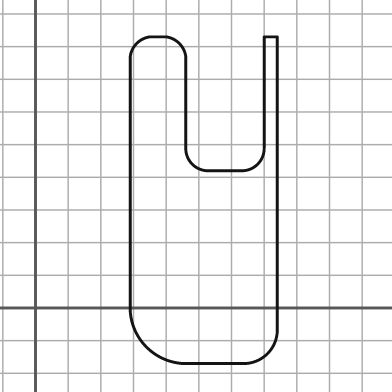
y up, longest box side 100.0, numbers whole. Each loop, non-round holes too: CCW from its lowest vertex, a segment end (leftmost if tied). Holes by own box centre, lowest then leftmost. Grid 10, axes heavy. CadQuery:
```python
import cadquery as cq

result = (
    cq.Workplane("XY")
    .moveTo(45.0, -17.0)
    .lineTo(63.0, -17.0)
    .threePointArc((71.0, -14.0), (74.0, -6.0))
    .lineTo(74.0, 83.0)
    .lineTo(70.0, 83.0)
    .lineTo(70.0, 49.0)
    .threePointArc((68.0, 44.0), (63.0, 42.0))
    .lineTo(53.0, 42.0)
    .threePointArc((48.0, 44.0), (46.0, 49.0))
    .lineTo(46.0, 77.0)
    .threePointArc((44.0, 81.0), (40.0, 83.0))
    .lineTo(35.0, 83.0)
    .threePointArc((31.0, 81.0), (29.0, 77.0))
    .lineTo(29.0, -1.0)
    .threePointArc((34.0, -12.0), (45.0, -17.0))
    .close()
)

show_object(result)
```